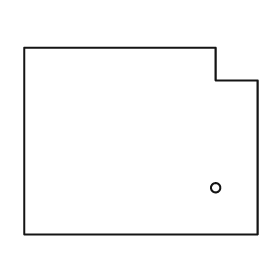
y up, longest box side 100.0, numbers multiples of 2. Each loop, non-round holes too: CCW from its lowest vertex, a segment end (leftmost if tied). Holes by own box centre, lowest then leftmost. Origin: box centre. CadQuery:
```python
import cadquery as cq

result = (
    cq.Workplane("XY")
    .moveTo(-50.0, -40.0)
    .lineTo(50.0, -40.0)
    .lineTo(50.0, 26.0)
    .lineTo(32.0, 26.0)
    .lineTo(32.0, 40.0)
    .lineTo(-50.0, 40.0)
    .close()
    .moveTo(32.0, -20.0)
    .circle(2.0)
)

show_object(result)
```